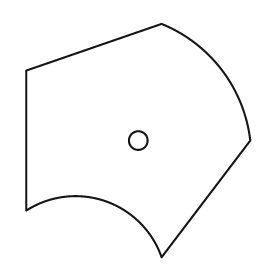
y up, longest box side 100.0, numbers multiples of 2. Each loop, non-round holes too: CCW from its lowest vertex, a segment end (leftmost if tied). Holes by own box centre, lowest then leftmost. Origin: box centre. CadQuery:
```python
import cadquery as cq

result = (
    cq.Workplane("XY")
    .moveTo(10.0, -50.0)
    .lineTo(48.0, 0.0)
    .threePointArc((36.0, 30.0), (10.0, 50.0))
    .lineTo(-48.0, 30.0)
    .lineTo(-48.0, -30.0)
    .threePointArc((-14.0, -26.0), (10.0, -50.0))
    .close()
    .moveTo(0.0, 0.0)
    .circle(4.0)
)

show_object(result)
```